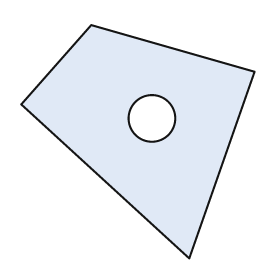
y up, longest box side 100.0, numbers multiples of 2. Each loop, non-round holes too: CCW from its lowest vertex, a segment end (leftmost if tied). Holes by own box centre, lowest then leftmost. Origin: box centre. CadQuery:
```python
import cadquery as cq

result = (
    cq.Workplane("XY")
    .moveTo(22.0, -50.0)
    .lineTo(50.0, 30.0)
    .lineTo(-20.0, 50.0)
    .lineTo(-50.0, 16.0)
    .close()
    .moveTo(6.0, 10.0)
    .circle(10.0)
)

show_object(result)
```